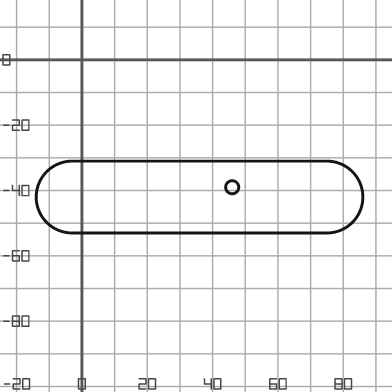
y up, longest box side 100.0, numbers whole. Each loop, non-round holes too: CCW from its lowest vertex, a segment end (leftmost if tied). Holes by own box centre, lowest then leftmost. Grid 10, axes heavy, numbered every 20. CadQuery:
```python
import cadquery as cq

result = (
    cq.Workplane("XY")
    .moveTo(-3.0, -53.0)
    .lineTo(75.0, -53.0)
    .threePointArc((86.0, -42.0), (75.0, -31.0))
    .lineTo(-3.0, -31.0)
    .threePointArc((-14.0, -42.0), (-3.0, -53.0))
    .close()
    .moveTo(46.0, -39.0)
    .circle(2.0)
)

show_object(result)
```